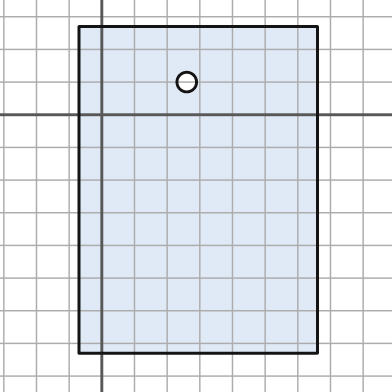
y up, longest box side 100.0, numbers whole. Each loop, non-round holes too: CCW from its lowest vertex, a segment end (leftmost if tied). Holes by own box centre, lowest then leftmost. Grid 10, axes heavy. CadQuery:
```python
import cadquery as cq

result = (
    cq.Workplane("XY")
    .moveTo(-7.0, -73.0)
    .lineTo(66.0, -73.0)
    .lineTo(66.0, 27.0)
    .lineTo(-7.0, 27.0)
    .close()
    .moveTo(26.0, 10.0)
    .circle(3.0)
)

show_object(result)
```